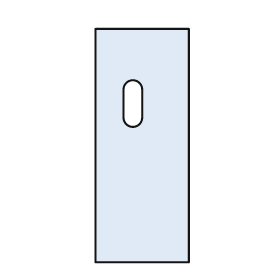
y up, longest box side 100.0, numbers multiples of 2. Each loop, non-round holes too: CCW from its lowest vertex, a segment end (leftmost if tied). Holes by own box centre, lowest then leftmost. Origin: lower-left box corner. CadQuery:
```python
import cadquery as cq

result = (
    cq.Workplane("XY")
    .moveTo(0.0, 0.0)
    .lineTo(40.0, 0.0)
    .lineTo(40.0, 100.0)
    .lineTo(0.0, 100.0)
    .close()
    .moveTo(12.0, 62.0)
    .threePointArc((16.0, 58.0), (20.0, 62.0))
    .lineTo(20.0, 74.0)
    .threePointArc((16.0, 78.0), (12.0, 74.0))
    .close()
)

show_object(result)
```